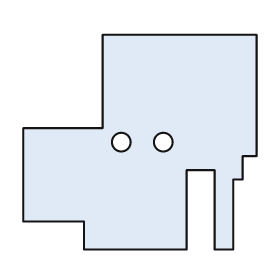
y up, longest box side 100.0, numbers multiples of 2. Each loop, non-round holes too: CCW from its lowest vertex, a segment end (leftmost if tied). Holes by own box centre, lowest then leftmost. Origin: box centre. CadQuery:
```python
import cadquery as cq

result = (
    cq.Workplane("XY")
    .moveTo(-24.0, -46.0)
    .lineTo(20.0, -46.0)
    .lineTo(20.0, -12.0)
    .lineTo(32.0, -12.0)
    .lineTo(32.0, -46.0)
    .lineTo(40.0, -46.0)
    .lineTo(40.0, -16.0)
    .lineTo(44.0, -16.0)
    .lineTo(44.0, -6.0)
    .lineTo(50.0, -6.0)
    .lineTo(50.0, 46.0)
    .lineTo(-16.0, 46.0)
    .lineTo(-16.0, 6.0)
    .lineTo(-50.0, 6.0)
    .lineTo(-50.0, -34.0)
    .lineTo(-24.0, -34.0)
    .close()
    .moveTo(-8.0, 0.0)
    .circle(4.0)
    .moveTo(10.0, 0.0)
    .circle(4.0)
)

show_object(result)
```